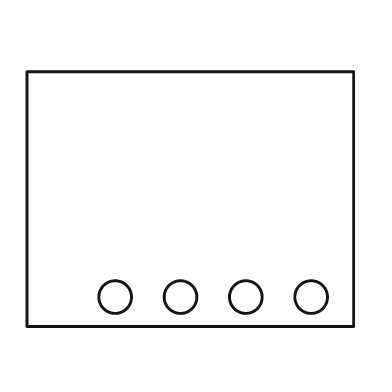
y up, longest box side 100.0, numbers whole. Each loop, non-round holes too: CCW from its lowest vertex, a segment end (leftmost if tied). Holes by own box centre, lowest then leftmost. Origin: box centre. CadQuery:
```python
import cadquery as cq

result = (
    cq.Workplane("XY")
    .moveTo(-50.0, -39.0)
    .lineTo(50.0, -39.0)
    .lineTo(50.0, 39.0)
    .lineTo(-50.0, 39.0)
    .close()
    .moveTo(-23.0, -30.0)
    .circle(5.0)
    .moveTo(-3.0, -30.0)
    .circle(5.0)
    .moveTo(17.0, -30.0)
    .circle(5.0)
    .moveTo(37.0, -30.0)
    .circle(5.0)
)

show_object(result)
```